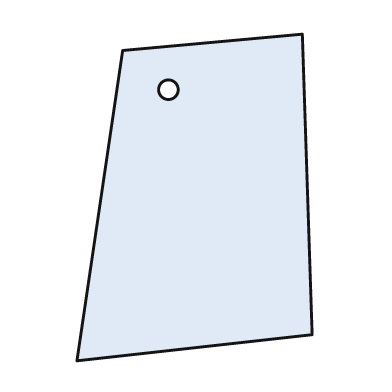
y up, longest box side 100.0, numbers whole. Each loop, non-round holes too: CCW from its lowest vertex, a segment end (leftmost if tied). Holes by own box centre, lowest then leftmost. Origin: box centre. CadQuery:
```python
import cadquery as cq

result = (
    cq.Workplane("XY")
    .moveTo(-36.0, -50.0)
    .lineTo(36.0, -42.0)
    .lineTo(33.0, 50.0)
    .lineTo(-22.0, 45.0)
    .close()
    .moveTo(-8.0, 33.0)
    .circle(3.0)
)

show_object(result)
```